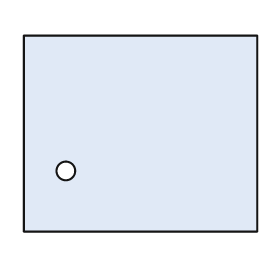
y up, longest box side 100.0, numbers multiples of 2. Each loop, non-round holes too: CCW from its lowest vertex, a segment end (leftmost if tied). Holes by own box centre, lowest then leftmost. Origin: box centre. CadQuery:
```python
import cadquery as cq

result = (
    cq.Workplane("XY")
    .moveTo(-50.0, -42.0)
    .lineTo(50.0, -42.0)
    .lineTo(50.0, 42.0)
    .lineTo(-50.0, 42.0)
    .close()
    .moveTo(-32.0, -16.0)
    .circle(4.0)
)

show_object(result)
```